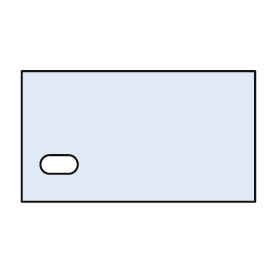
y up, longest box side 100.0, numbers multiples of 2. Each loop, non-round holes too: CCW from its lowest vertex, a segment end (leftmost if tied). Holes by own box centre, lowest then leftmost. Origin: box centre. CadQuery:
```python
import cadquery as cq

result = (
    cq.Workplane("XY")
    .moveTo(-50.0, -28.0)
    .lineTo(50.0, -28.0)
    .lineTo(50.0, 28.0)
    .lineTo(-50.0, 28.0)
    .close()
    .moveTo(-38.0, -16.0)
    .lineTo(-30.0, -16.0)
    .threePointArc((-26.0, -12.0), (-30.0, -8.0))
    .lineTo(-38.0, -8.0)
    .threePointArc((-42.0, -12.0), (-38.0, -16.0))
    .close()
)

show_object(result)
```